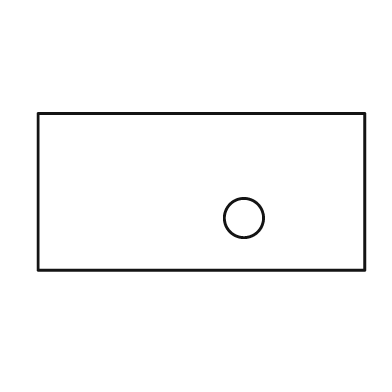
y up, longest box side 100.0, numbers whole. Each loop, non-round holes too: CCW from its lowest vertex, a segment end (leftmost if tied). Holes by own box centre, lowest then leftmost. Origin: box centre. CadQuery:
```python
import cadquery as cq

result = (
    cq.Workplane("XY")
    .moveTo(-50.0, -24.0)
    .lineTo(50.0, -24.0)
    .lineTo(50.0, 24.0)
    .lineTo(-50.0, 24.0)
    .close()
    .moveTo(13.0, -8.0)
    .circle(6.0)
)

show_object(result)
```